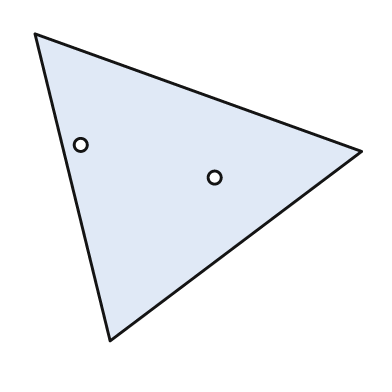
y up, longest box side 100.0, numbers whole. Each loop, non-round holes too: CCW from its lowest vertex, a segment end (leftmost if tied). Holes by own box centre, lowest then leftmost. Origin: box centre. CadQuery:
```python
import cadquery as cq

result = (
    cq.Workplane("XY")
    .moveTo(-27.0, -47.0)
    .lineTo(50.0, 11.0)
    .lineTo(-50.0, 47.0)
    .close()
    .moveTo(5.0, 3.0)
    .circle(2.0)
    .moveTo(-36.0, 13.0)
    .circle(2.0)
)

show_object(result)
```